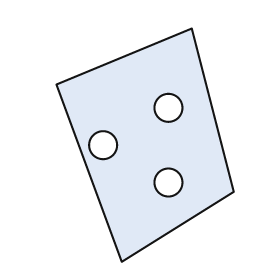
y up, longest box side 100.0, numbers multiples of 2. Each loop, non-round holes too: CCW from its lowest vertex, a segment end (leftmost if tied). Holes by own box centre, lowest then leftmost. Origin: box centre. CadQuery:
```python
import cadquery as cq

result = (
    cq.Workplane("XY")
    .moveTo(-10.0, -50.0)
    .lineTo(38.0, -20.0)
    .lineTo(20.0, 50.0)
    .lineTo(-38.0, 26.0)
    .close()
    .moveTo(10.0, -16.0)
    .circle(6.0)
    .moveTo(-18.0, 0.0)
    .circle(6.0)
    .moveTo(10.0, 16.0)
    .circle(6.0)
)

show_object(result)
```